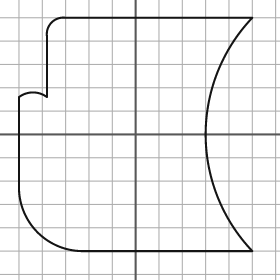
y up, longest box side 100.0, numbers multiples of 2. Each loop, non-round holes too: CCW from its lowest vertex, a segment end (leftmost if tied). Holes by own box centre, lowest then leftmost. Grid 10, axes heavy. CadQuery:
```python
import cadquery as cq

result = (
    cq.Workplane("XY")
    .moveTo(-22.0, -50.0)
    .lineTo(50.0, -50.0)
    .threePointArc((30.0, 0.0), (50.0, 50.0))
    .lineTo(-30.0, 50.0)
    .threePointArc((-36.0, 48.0), (-38.0, 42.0))
    .lineTo(-38.0, 16.0)
    .threePointArc((-44.0, 18.0), (-50.0, 16.0))
    .lineTo(-50.0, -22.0)
    .threePointArc((-42.0, -42.0), (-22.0, -50.0))
    .close()
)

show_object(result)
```